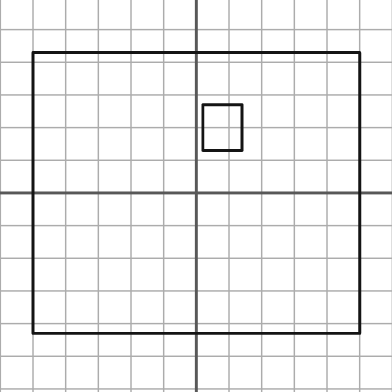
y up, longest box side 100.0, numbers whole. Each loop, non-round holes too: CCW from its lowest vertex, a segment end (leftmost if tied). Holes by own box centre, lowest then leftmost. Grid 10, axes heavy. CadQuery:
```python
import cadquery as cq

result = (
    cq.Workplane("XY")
    .moveTo(-50.0, -43.0)
    .lineTo(50.0, -43.0)
    .lineTo(50.0, 43.0)
    .lineTo(-50.0, 43.0)
    .close()
    .moveTo(2.0, 13.0)
    .lineTo(14.0, 13.0)
    .lineTo(14.0, 27.0)
    .lineTo(2.0, 27.0)
    .close()
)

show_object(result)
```